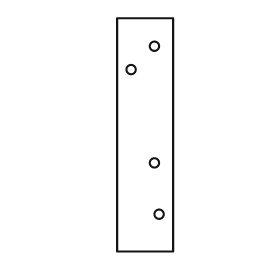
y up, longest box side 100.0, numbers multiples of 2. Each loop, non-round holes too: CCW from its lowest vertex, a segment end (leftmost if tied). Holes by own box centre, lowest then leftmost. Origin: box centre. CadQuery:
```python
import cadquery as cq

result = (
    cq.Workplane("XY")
    .moveTo(-12.0, -50.0)
    .lineTo(12.0, -50.0)
    .lineTo(12.0, 50.0)
    .lineTo(-12.0, 50.0)
    .close()
    .moveTo(6.0, -34.0)
    .circle(2.0)
    .moveTo(4.0, -12.0)
    .circle(2.0)
    .moveTo(-6.0, 28.0)
    .circle(2.0)
    .moveTo(4.0, 38.0)
    .circle(2.0)
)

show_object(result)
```